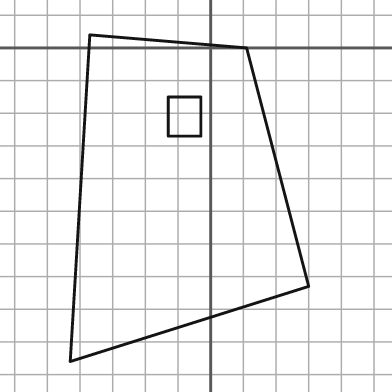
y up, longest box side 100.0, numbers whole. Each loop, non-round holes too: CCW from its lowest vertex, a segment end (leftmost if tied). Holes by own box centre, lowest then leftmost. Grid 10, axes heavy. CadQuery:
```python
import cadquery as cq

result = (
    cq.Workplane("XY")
    .moveTo(-43.0, -96.0)
    .lineTo(30.0, -73.0)
    .lineTo(11.0, 0.0)
    .lineTo(-37.0, 4.0)
    .close()
    .moveTo(-13.0, -27.0)
    .lineTo(-3.0, -27.0)
    .lineTo(-3.0, -15.0)
    .lineTo(-13.0, -15.0)
    .close()
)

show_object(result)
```